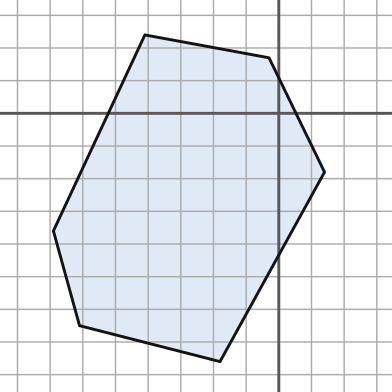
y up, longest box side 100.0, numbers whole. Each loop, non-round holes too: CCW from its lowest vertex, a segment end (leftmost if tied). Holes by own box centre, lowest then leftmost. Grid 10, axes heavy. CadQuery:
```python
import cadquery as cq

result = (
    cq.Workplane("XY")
    .moveTo(-18.0, -76.0)
    .lineTo(14.0, -18.0)
    .lineTo(-3.0, 17.0)
    .lineTo(-41.0, 24.0)
    .lineTo(-69.0, -36.0)
    .lineTo(-61.0, -65.0)
    .close()
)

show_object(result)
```